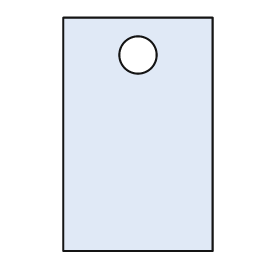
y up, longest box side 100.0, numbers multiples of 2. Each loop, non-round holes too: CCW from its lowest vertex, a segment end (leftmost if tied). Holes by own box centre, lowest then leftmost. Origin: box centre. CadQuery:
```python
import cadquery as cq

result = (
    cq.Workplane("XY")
    .moveTo(-32.0, -50.0)
    .lineTo(32.0, -50.0)
    .lineTo(32.0, 50.0)
    .lineTo(-32.0, 50.0)
    .close()
    .moveTo(0.0, 34.0)
    .circle(8.0)
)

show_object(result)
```